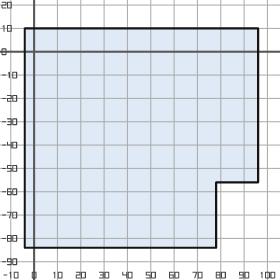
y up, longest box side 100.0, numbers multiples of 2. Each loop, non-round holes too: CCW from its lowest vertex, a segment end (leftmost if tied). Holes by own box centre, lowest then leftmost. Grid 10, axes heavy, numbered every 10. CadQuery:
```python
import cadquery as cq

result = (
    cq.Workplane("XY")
    .moveTo(-4.0, -84.0)
    .lineTo(78.0, -84.0)
    .lineTo(78.0, -56.0)
    .lineTo(96.0, -56.0)
    .lineTo(96.0, 10.0)
    .lineTo(-4.0, 10.0)
    .close()
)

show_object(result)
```